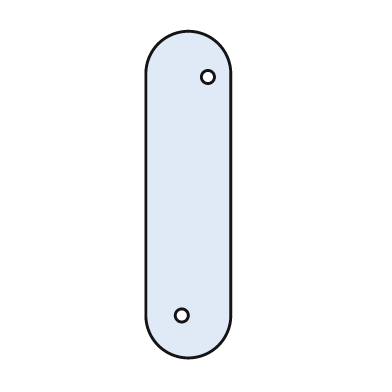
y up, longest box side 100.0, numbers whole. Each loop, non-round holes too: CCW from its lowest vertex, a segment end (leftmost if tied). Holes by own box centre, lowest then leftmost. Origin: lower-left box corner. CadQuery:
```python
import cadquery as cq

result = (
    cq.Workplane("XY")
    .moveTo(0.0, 13.0)
    .threePointArc((13.0, 0.0), (26.0, 13.0))
    .lineTo(26.0, 87.0)
    .threePointArc((13.0, 100.0), (0.0, 87.0))
    .close()
    .moveTo(11.0, 13.0)
    .circle(2.0)
    .moveTo(19.0, 86.0)
    .circle(2.0)
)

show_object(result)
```